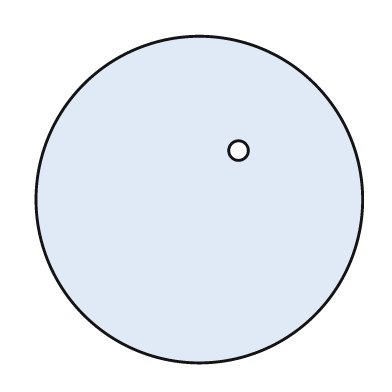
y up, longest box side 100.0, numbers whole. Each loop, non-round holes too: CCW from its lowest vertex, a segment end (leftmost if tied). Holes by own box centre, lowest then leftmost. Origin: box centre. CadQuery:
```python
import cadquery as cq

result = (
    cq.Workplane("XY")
    .moveTo(0.0, 0.0)
    .circle(50.0)
    .moveTo(12.0, 15.0)
    .circle(3.0)
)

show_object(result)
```